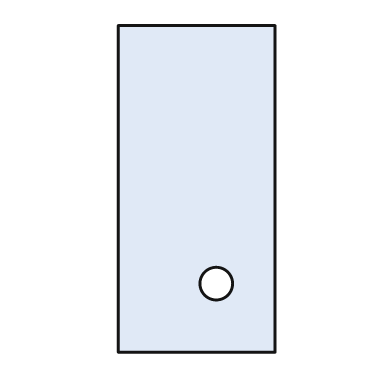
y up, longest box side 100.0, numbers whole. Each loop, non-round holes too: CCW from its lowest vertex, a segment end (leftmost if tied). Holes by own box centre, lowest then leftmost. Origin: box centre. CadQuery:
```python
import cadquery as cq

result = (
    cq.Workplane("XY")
    .moveTo(-24.0, -50.0)
    .lineTo(24.0, -50.0)
    .lineTo(24.0, 50.0)
    .lineTo(-24.0, 50.0)
    .close()
    .moveTo(6.0, -29.0)
    .circle(5.0)
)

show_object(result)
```